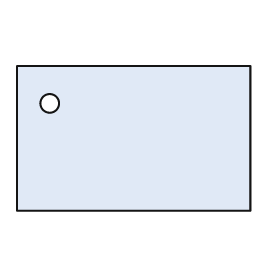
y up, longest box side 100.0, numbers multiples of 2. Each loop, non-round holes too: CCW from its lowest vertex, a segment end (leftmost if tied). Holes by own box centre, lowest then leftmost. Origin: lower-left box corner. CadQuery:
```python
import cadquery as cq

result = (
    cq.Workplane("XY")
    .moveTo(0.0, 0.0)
    .lineTo(100.0, 0.0)
    .lineTo(100.0, 62.0)
    .lineTo(0.0, 62.0)
    .close()
    .moveTo(14.0, 46.0)
    .circle(4.0)
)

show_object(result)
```